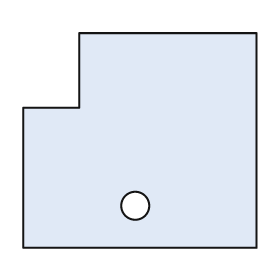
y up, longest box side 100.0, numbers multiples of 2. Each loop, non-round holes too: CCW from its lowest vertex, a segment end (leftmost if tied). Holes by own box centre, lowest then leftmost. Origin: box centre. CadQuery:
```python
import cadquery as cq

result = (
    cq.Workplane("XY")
    .moveTo(-50.0, -46.0)
    .lineTo(50.0, -46.0)
    .lineTo(50.0, 46.0)
    .lineTo(-26.0, 46.0)
    .lineTo(-26.0, 14.0)
    .lineTo(-50.0, 14.0)
    .close()
    .moveTo(-2.0, -28.0)
    .circle(6.0)
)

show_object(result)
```